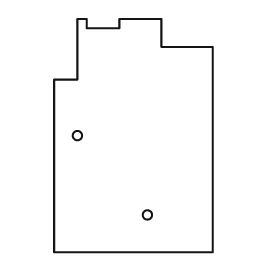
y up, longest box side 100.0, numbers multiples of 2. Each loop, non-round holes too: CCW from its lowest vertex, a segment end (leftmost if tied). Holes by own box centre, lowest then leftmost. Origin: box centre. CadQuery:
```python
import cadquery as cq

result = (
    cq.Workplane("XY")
    .moveTo(-34.0, -50.0)
    .lineTo(34.0, -50.0)
    .lineTo(34.0, 38.0)
    .lineTo(12.0, 38.0)
    .lineTo(12.0, 50.0)
    .lineTo(-6.0, 50.0)
    .lineTo(-6.0, 46.0)
    .lineTo(-20.0, 46.0)
    .lineTo(-20.0, 50.0)
    .lineTo(-24.0, 50.0)
    .lineTo(-24.0, 24.0)
    .lineTo(-34.0, 24.0)
    .close()
    .moveTo(6.0, -34.0)
    .circle(2.0)
    .moveTo(-24.0, 0.0)
    .circle(2.0)
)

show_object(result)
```